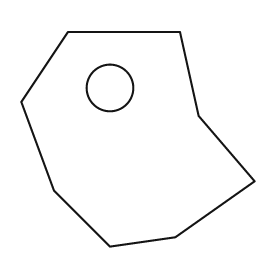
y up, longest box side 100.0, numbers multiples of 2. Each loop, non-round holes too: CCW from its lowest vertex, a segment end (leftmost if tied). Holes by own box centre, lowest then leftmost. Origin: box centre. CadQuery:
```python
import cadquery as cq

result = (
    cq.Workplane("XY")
    .moveTo(-12.0, -46.0)
    .lineTo(16.0, -42.0)
    .lineTo(50.0, -18.0)
    .lineTo(26.0, 10.0)
    .lineTo(18.0, 46.0)
    .lineTo(-30.0, 46.0)
    .lineTo(-50.0, 16.0)
    .lineTo(-36.0, -22.0)
    .close()
    .moveTo(-12.0, 22.0)
    .circle(10.0)
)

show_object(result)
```